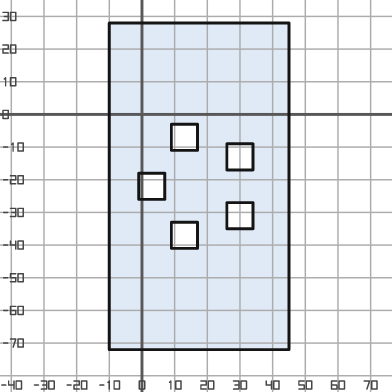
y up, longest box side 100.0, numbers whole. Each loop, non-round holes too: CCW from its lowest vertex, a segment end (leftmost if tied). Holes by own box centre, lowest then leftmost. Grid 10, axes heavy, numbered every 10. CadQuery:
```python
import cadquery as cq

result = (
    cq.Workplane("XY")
    .moveTo(-10.0, -72.0)
    .lineTo(45.0, -72.0)
    .lineTo(45.0, 28.0)
    .lineTo(-10.0, 28.0)
    .close()
    .moveTo(9.0, -41.0)
    .lineTo(17.0, -41.0)
    .lineTo(17.0, -33.0)
    .lineTo(9.0, -33.0)
    .close()
    .moveTo(26.0, -35.0)
    .lineTo(34.0, -35.0)
    .lineTo(34.0, -27.0)
    .lineTo(26.0, -27.0)
    .close()
    .moveTo(-1.0, -26.0)
    .lineTo(7.0, -26.0)
    .lineTo(7.0, -18.0)
    .lineTo(-1.0, -18.0)
    .close()
    .moveTo(26.0, -17.0)
    .lineTo(34.0, -17.0)
    .lineTo(34.0, -9.0)
    .lineTo(26.0, -9.0)
    .close()
    .moveTo(9.0, -11.0)
    .lineTo(17.0, -11.0)
    .lineTo(17.0, -3.0)
    .lineTo(9.0, -3.0)
    .close()
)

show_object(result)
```